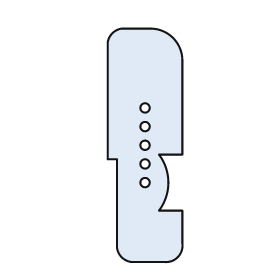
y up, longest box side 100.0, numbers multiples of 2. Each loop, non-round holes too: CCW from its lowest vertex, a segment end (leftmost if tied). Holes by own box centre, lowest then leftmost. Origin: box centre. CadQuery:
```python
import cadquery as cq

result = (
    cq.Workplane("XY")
    .moveTo(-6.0, -50.0)
    .lineTo(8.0, -50.0)
    .threePointArc((14.0, -48.0), (16.0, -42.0))
    .lineTo(16.0, -28.0)
    .lineTo(6.0, -28.0)
    .threePointArc((10.0, -16.0), (6.0, -4.0))
    .lineTo(16.0, -4.0)
    .lineTo(16.0, 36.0)
    .threePointArc((12.0, 46.0), (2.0, 50.0))
    .lineTo(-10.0, 50.0)
    .threePointArc((-14.0, 48.0), (-16.0, 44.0))
    .lineTo(-16.0, -6.0)
    .lineTo(-12.0, -6.0)
    .lineTo(-12.0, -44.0)
    .threePointArc((-10.0, -48.0), (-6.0, -50.0))
    .close()
    .moveTo(0.0, -16.0)
    .circle(2.0)
    .moveTo(0.0, -8.0)
    .circle(2.0)
    .moveTo(0.0, 0.0)
    .circle(2.0)
    .moveTo(0.0, 8.0)
    .circle(2.0)
    .moveTo(0.0, 16.0)
    .circle(2.0)
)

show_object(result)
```